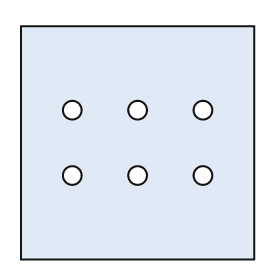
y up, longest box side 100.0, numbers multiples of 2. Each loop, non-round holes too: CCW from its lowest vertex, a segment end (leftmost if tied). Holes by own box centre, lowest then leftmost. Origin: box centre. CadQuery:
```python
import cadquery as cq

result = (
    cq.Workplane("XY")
    .moveTo(-50.0, -50.0)
    .lineTo(50.0, -50.0)
    .lineTo(50.0, 50.0)
    .lineTo(-50.0, 50.0)
    .close()
    .moveTo(-28.0, -14.0)
    .circle(4.0)
    .moveTo(0.0, -14.0)
    .circle(4.0)
    .moveTo(28.0, -14.0)
    .circle(4.0)
    .moveTo(-28.0, 14.0)
    .circle(4.0)
    .moveTo(0.0, 14.0)
    .circle(4.0)
    .moveTo(28.0, 14.0)
    .circle(4.0)
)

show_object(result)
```